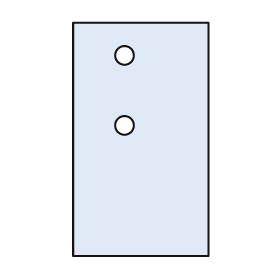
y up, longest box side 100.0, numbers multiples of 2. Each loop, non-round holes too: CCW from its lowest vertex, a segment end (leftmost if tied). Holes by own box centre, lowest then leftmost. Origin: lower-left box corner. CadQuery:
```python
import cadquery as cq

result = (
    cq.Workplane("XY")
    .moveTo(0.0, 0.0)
    .lineTo(58.0, 0.0)
    .lineTo(58.0, 100.0)
    .lineTo(0.0, 100.0)
    .close()
    .moveTo(22.0, 56.0)
    .circle(4.0)
    .moveTo(22.0, 86.0)
    .circle(4.0)
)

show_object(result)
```